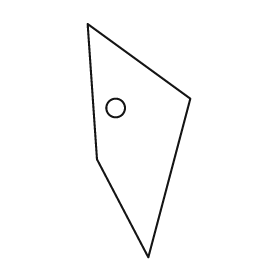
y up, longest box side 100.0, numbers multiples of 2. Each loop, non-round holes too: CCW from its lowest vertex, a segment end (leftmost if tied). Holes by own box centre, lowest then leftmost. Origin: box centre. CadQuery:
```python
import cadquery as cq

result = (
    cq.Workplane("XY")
    .moveTo(4.0, -50.0)
    .lineTo(22.0, 18.0)
    .lineTo(-22.0, 50.0)
    .lineTo(-18.0, -8.0)
    .close()
    .moveTo(-10.0, 14.0)
    .circle(4.0)
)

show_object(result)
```